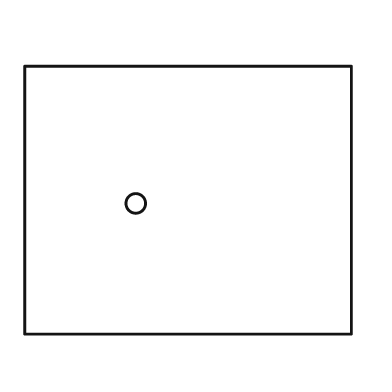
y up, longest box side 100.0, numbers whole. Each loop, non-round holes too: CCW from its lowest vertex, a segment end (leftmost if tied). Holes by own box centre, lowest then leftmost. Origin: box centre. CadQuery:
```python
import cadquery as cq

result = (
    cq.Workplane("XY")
    .moveTo(-50.0, -41.0)
    .lineTo(50.0, -41.0)
    .lineTo(50.0, 41.0)
    .lineTo(-50.0, 41.0)
    .close()
    .moveTo(-16.0, -1.0)
    .circle(3.0)
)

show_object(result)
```